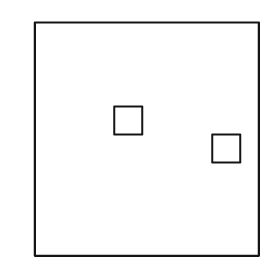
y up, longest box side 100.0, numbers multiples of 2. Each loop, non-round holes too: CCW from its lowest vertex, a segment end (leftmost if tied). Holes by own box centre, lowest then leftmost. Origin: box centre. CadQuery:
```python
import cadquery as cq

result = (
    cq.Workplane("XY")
    .moveTo(-48.0, -50.0)
    .lineTo(48.0, -50.0)
    .lineTo(48.0, 50.0)
    .lineTo(-48.0, 50.0)
    .close()
    .moveTo(28.0, -10.0)
    .lineTo(40.0, -10.0)
    .lineTo(40.0, 2.0)
    .lineTo(28.0, 2.0)
    .close()
    .moveTo(-14.0, 2.0)
    .lineTo(-2.0, 2.0)
    .lineTo(-2.0, 14.0)
    .lineTo(-14.0, 14.0)
    .close()
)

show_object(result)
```